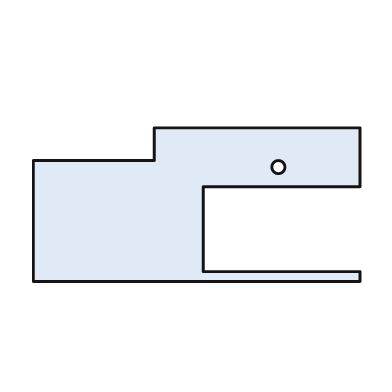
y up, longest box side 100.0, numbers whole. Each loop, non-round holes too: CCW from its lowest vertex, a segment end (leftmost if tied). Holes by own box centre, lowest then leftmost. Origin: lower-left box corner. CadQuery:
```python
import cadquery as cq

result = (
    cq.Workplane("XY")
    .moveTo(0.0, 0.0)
    .lineTo(100.0, 0.0)
    .lineTo(100.0, 3.0)
    .lineTo(52.0, 3.0)
    .lineTo(52.0, 29.0)
    .lineTo(100.0, 29.0)
    .lineTo(100.0, 47.0)
    .lineTo(37.0, 47.0)
    .lineTo(37.0, 37.0)
    .lineTo(0.0, 37.0)
    .close()
    .moveTo(75.0, 35.0)
    .circle(2.0)
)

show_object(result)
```